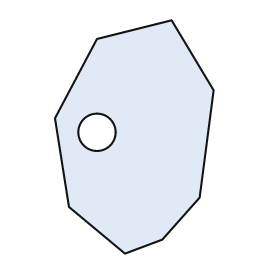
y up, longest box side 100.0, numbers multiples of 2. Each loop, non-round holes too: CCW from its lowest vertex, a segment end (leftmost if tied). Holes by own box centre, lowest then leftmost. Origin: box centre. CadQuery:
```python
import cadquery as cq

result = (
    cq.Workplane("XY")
    .moveTo(-4.0, -50.0)
    .lineTo(12.0, -44.0)
    .lineTo(28.0, -26.0)
    .lineTo(34.0, 20.0)
    .lineTo(16.0, 50.0)
    .lineTo(-16.0, 42.0)
    .lineTo(-34.0, 8.0)
    .lineTo(-28.0, -30.0)
    .close()
    .moveTo(-16.0, 2.0)
    .circle(8.0)
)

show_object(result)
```